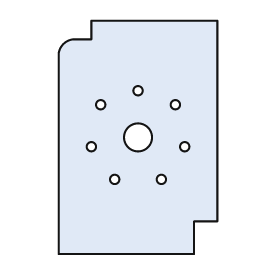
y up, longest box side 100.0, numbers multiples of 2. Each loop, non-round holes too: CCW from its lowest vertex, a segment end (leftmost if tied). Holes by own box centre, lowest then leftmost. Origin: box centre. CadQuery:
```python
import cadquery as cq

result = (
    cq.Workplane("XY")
    .moveTo(-34.0, -50.0)
    .lineTo(24.0, -50.0)
    .lineTo(24.0, -36.0)
    .lineTo(34.0, -36.0)
    .lineTo(34.0, 50.0)
    .lineTo(-20.0, 50.0)
    .lineTo(-20.0, 42.0)
    .lineTo(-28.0, 42.0)
    .threePointArc((-32.0, 40.0), (-34.0, 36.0))
    .close()
    .moveTo(-10.0, -18.0)
    .circle(2.0)
    .moveTo(10.0, -18.0)
    .circle(2.0)
    .moveTo(-20.0, -4.0)
    .circle(2.0)
    .moveTo(20.0, -4.0)
    .circle(2.0)
    .moveTo(0.0, 0.0)
    .circle(6.0)
    .moveTo(-16.0, 14.0)
    .circle(2.0)
    .moveTo(16.0, 14.0)
    .circle(2.0)
    .moveTo(0.0, 20.0)
    .circle(2.0)
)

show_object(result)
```